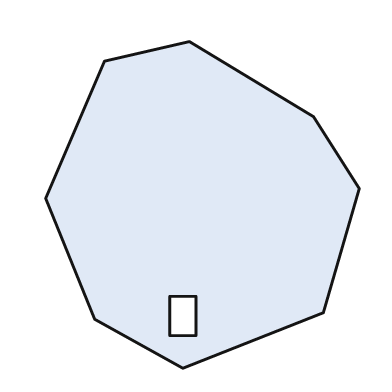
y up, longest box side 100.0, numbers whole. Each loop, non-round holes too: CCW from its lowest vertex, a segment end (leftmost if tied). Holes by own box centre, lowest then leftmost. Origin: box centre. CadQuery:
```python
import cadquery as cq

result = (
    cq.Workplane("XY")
    .moveTo(-6.0, -50.0)
    .lineTo(37.0, -33.0)
    .lineTo(48.0, 5.0)
    .lineTo(34.0, 27.0)
    .lineTo(-4.0, 50.0)
    .lineTo(-30.0, 44.0)
    .lineTo(-48.0, 2.0)
    .lineTo(-33.0, -35.0)
    .close()
    .moveTo(-10.0, -40.0)
    .lineTo(-2.0, -40.0)
    .lineTo(-2.0, -28.0)
    .lineTo(-10.0, -28.0)
    .close()
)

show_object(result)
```